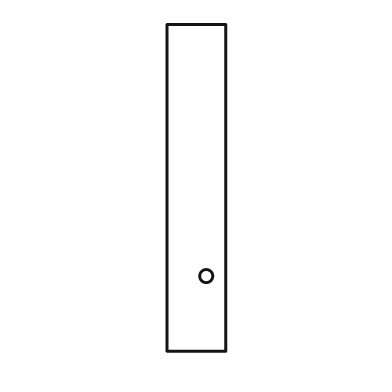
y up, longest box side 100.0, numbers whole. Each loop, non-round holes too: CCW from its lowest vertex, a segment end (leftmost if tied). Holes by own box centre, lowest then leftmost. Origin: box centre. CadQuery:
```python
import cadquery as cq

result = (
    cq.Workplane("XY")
    .moveTo(-9.0, -50.0)
    .lineTo(9.0, -50.0)
    .lineTo(9.0, 50.0)
    .lineTo(-9.0, 50.0)
    .close()
    .moveTo(3.0, -27.0)
    .circle(2.0)
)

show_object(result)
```